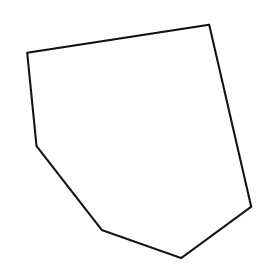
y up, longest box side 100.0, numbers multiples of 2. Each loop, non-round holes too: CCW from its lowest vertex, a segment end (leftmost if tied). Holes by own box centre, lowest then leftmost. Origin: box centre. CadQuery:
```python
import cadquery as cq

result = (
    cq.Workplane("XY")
    .moveTo(18.0, -50.0)
    .lineTo(48.0, -28.0)
    .lineTo(30.0, 50.0)
    .lineTo(-48.0, 38.0)
    .lineTo(-44.0, -2.0)
    .lineTo(-16.0, -38.0)
    .close()
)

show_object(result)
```